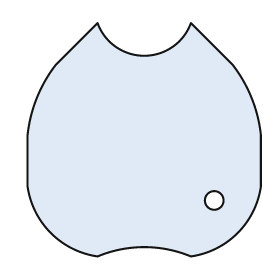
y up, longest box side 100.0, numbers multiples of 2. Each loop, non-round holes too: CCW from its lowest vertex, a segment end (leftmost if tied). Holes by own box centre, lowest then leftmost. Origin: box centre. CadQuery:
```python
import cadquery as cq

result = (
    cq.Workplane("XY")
    .moveTo(-20.0, -50.0)
    .threePointArc((0.0, -46.0), (20.0, -50.0))
    .threePointArc((40.0, -40.0), (50.0, -20.0))
    .lineTo(50.0, 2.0)
    .threePointArc((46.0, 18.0), (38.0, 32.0))
    .lineTo(20.0, 50.0)
    .threePointArc((0.0, 36.0), (-20.0, 50.0))
    .lineTo(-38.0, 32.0)
    .threePointArc((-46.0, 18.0), (-50.0, 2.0))
    .lineTo(-50.0, -20.0)
    .threePointArc((-40.0, -40.0), (-20.0, -50.0))
    .close()
    .moveTo(30.0, -26.0)
    .circle(4.0)
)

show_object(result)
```